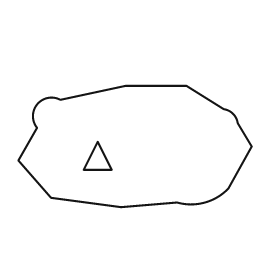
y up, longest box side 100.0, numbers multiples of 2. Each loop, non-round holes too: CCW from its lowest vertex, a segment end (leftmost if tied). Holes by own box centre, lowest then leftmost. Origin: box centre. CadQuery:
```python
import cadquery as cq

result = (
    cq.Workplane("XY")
    .moveTo(-6.0, -26.0)
    .lineTo(18.0, -24.0)
    .threePointArc((30.0, -24.0), (40.0, -18.0))
    .lineTo(50.0, 0.0)
    .lineTo(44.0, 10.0)
    .threePointArc((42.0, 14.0), (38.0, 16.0))
    .lineTo(22.0, 26.0)
    .lineTo(-4.0, 26.0)
    .lineTo(-32.0, 20.0)
    .threePointArc((-42.0, 18.0), (-42.0, 8.0))
    .lineTo(-50.0, -6.0)
    .lineTo(-36.0, -22.0)
    .close()
    .moveTo(-22.0, -10.0)
    .lineTo(-10.0, -10.0)
    .lineTo(-16.0, 2.0)
    .close()
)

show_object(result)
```